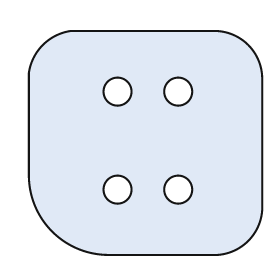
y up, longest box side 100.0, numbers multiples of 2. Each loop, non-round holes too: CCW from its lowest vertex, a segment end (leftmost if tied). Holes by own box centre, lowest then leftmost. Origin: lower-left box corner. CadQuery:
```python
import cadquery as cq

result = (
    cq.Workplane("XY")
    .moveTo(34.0, 0.0)
    .lineTo(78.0, 0.0)
    .threePointArc((94.0, 6.0), (100.0, 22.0))
    .lineTo(100.0, 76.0)
    .threePointArc((94.0, 90.0), (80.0, 96.0))
    .lineTo(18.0, 96.0)
    .threePointArc((6.0, 90.0), (0.0, 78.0))
    .lineTo(0.0, 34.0)
    .threePointArc((10.0, 10.0), (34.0, 0.0))
    .close()
    .moveTo(38.0, 28.0)
    .circle(6.0)
    .moveTo(64.0, 28.0)
    .circle(6.0)
    .moveTo(38.0, 70.0)
    .circle(6.0)
    .moveTo(64.0, 70.0)
    .circle(6.0)
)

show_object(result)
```